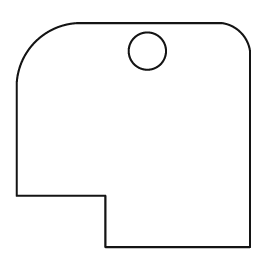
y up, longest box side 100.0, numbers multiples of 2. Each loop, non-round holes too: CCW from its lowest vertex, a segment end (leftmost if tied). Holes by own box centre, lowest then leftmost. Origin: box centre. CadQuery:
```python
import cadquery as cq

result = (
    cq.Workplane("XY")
    .moveTo(-12.0, -48.0)
    .lineTo(50.0, -48.0)
    .lineTo(50.0, 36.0)
    .threePointArc((46.0, 44.0), (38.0, 48.0))
    .lineTo(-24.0, 48.0)
    .threePointArc((-42.0, 40.0), (-50.0, 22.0))
    .lineTo(-50.0, -26.0)
    .lineTo(-12.0, -26.0)
    .close()
    .moveTo(6.0, 36.0)
    .circle(8.0)
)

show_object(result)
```